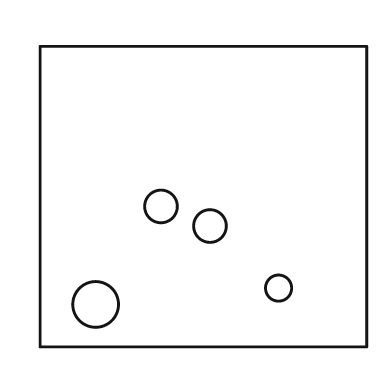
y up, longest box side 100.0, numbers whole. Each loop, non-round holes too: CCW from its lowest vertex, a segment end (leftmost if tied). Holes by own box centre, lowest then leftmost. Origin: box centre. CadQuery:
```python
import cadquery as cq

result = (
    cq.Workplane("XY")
    .moveTo(-50.0, -46.0)
    .lineTo(50.0, -46.0)
    .lineTo(50.0, 46.0)
    .lineTo(-50.0, 46.0)
    .close()
    .moveTo(-33.0, -33.0)
    .circle(7.0)
    .moveTo(23.0, -28.0)
    .circle(4.0)
    .moveTo(2.0, -9.0)
    .circle(5.0)
    .moveTo(-13.0, -3.0)
    .circle(5.0)
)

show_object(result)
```